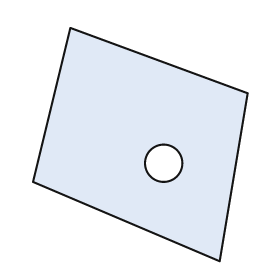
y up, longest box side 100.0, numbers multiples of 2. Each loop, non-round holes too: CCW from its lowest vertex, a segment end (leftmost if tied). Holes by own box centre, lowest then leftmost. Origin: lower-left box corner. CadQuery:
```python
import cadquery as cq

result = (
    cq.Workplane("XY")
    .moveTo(80.0, 0.0)
    .lineTo(92.0, 72.0)
    .lineTo(16.0, 100.0)
    .lineTo(0.0, 34.0)
    .close()
    .moveTo(56.0, 42.0)
    .circle(8.0)
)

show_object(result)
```